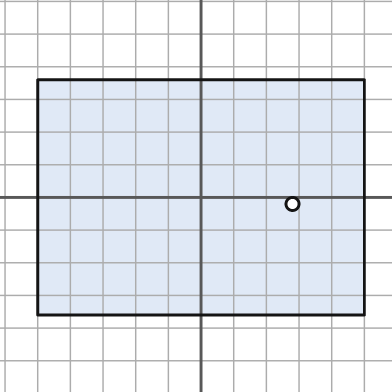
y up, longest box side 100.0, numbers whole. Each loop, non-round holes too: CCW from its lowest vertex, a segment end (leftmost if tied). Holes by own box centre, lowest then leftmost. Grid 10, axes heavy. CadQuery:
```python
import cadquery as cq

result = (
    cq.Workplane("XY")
    .moveTo(-50.0, -36.0)
    .lineTo(50.0, -36.0)
    .lineTo(50.0, 36.0)
    .lineTo(-50.0, 36.0)
    .close()
    .moveTo(28.0, -2.0)
    .circle(2.0)
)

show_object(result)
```